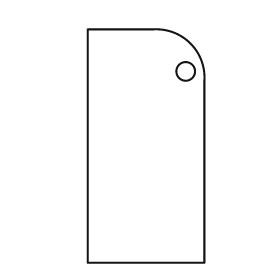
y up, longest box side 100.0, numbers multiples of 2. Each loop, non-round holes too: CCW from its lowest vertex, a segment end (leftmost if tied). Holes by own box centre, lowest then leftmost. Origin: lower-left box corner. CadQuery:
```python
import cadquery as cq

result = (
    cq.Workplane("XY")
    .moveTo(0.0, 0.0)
    .lineTo(50.0, 0.0)
    .lineTo(50.0, 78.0)
    .threePointArc((44.0, 94.0), (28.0, 100.0))
    .lineTo(0.0, 100.0)
    .close()
    .moveTo(42.0, 82.0)
    .circle(4.0)
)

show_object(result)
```